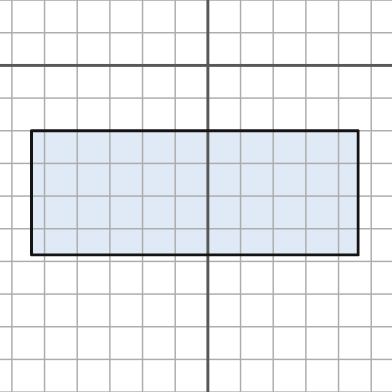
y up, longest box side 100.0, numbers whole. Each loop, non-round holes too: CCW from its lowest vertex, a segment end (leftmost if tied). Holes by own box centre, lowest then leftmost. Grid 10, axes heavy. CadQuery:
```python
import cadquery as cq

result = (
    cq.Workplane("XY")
    .moveTo(-54.0, -58.0)
    .lineTo(46.0, -58.0)
    .lineTo(46.0, -20.0)
    .lineTo(-54.0, -20.0)
    .close()
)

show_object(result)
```